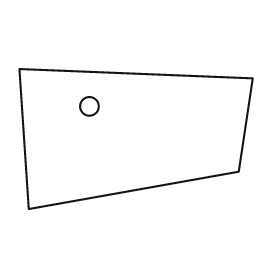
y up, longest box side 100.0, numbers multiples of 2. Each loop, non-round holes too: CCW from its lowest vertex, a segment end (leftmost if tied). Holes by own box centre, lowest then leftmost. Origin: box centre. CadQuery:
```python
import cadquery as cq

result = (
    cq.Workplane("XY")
    .moveTo(-46.0, -30.0)
    .lineTo(44.0, -14.0)
    .lineTo(50.0, 26.0)
    .lineTo(-50.0, 30.0)
    .close()
    .moveTo(-20.0, 14.0)
    .circle(4.0)
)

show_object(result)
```